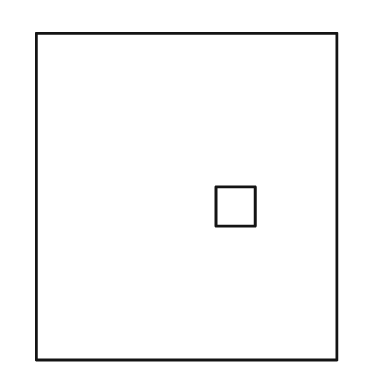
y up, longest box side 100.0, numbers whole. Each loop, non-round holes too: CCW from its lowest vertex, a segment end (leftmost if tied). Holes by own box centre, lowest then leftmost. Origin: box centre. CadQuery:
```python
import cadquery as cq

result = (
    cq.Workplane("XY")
    .moveTo(-46.0, -50.0)
    .lineTo(46.0, -50.0)
    .lineTo(46.0, 50.0)
    .lineTo(-46.0, 50.0)
    .close()
    .moveTo(9.0, -9.0)
    .lineTo(21.0, -9.0)
    .lineTo(21.0, 3.0)
    .lineTo(9.0, 3.0)
    .close()
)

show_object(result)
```